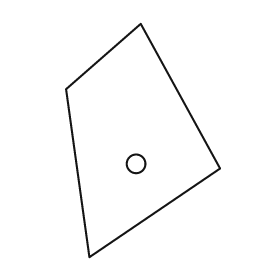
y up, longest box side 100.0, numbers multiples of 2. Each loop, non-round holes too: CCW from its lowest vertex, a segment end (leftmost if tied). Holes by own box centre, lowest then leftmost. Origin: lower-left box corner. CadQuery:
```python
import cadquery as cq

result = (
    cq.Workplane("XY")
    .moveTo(10.0, 0.0)
    .lineTo(66.0, 38.0)
    .lineTo(32.0, 100.0)
    .lineTo(0.0, 72.0)
    .close()
    .moveTo(30.0, 40.0)
    .circle(4.0)
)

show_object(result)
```